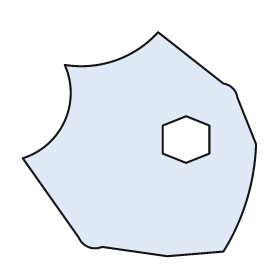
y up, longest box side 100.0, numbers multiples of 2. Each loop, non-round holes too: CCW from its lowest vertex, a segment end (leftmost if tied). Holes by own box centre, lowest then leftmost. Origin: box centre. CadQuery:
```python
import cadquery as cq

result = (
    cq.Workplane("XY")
    .moveTo(12.0, -48.0)
    .lineTo(36.0, -46.0)
    .threePointArc((46.0, -24.0), (50.0, 0.0))
    .lineTo(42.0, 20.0)
    .threePointArc((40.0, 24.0), (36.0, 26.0))
    .lineTo(8.0, 48.0)
    .threePointArc((-10.0, 36.0), (-32.0, 34.0))
    .threePointArc((-32.0, 10.0), (-50.0, -6.0))
    .lineTo(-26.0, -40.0)
    .threePointArc((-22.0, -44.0), (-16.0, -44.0))
    .close()
    .moveTo(20.0, -8.0)
    .lineTo(30.0, -4.0)
    .lineTo(30.0, 8.0)
    .lineTo(20.0, 12.0)
    .lineTo(10.0, 8.0)
    .lineTo(10.0, -4.0)
    .close()
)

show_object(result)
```